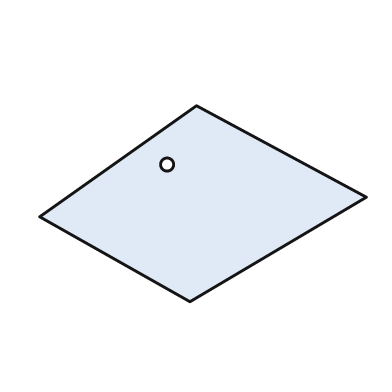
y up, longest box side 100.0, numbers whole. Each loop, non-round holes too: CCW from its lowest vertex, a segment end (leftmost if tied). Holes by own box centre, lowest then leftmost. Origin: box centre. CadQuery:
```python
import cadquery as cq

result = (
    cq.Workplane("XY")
    .moveTo(-4.0, -30.0)
    .lineTo(50.0, 2.0)
    .lineTo(-2.0, 30.0)
    .lineTo(-50.0, -4.0)
    .close()
    .moveTo(-11.0, 12.0)
    .circle(2.0)
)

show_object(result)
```